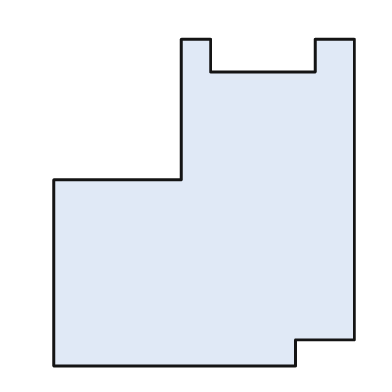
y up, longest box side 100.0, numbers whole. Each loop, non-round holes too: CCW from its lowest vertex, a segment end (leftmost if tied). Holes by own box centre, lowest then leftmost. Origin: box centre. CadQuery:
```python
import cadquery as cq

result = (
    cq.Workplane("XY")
    .moveTo(-46.0, -50.0)
    .lineTo(28.0, -50.0)
    .lineTo(28.0, -42.0)
    .lineTo(46.0, -42.0)
    .lineTo(46.0, 50.0)
    .lineTo(34.0, 50.0)
    .lineTo(34.0, 40.0)
    .lineTo(2.0, 40.0)
    .lineTo(2.0, 50.0)
    .lineTo(-7.0, 50.0)
    .lineTo(-7.0, 7.0)
    .lineTo(-46.0, 7.0)
    .close()
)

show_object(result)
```